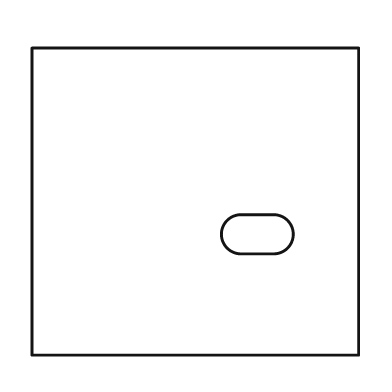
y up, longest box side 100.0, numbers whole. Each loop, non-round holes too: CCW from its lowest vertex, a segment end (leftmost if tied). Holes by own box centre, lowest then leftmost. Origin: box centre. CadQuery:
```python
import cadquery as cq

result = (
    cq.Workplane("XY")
    .moveTo(-50.0, -47.0)
    .lineTo(50.0, -47.0)
    .lineTo(50.0, 47.0)
    .lineTo(-50.0, 47.0)
    .close()
    .moveTo(14.0, -16.0)
    .lineTo(24.0, -16.0)
    .threePointArc((30.0, -10.0), (24.0, -4.0))
    .lineTo(14.0, -4.0)
    .threePointArc((8.0, -10.0), (14.0, -16.0))
    .close()
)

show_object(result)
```